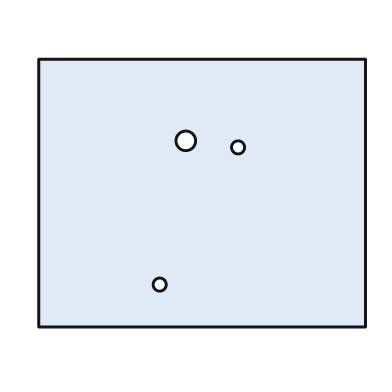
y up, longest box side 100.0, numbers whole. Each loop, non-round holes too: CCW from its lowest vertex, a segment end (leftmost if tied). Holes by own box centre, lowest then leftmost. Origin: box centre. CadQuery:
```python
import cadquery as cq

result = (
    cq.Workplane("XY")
    .moveTo(-50.0, -41.0)
    .lineTo(50.0, -41.0)
    .lineTo(50.0, 41.0)
    .lineTo(-50.0, 41.0)
    .close()
    .moveTo(-13.0, -28.0)
    .circle(2.0)
    .moveTo(11.0, 14.0)
    .circle(2.0)
    .moveTo(-5.0, 16.0)
    .circle(3.0)
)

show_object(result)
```